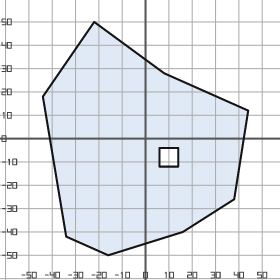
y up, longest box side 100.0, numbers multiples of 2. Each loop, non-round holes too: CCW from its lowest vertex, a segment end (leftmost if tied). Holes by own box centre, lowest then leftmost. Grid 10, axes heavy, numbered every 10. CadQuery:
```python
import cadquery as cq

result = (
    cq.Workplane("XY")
    .moveTo(-16.0, -50.0)
    .lineTo(16.0, -40.0)
    .lineTo(38.0, -26.0)
    .lineTo(44.0, 12.0)
    .lineTo(8.0, 28.0)
    .lineTo(-22.0, 50.0)
    .lineTo(-44.0, 18.0)
    .lineTo(-34.0, -42.0)
    .close()
    .moveTo(6.0, -12.0)
    .lineTo(14.0, -12.0)
    .lineTo(14.0, -4.0)
    .lineTo(6.0, -4.0)
    .close()
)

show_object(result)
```